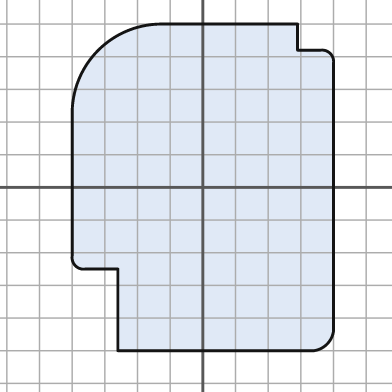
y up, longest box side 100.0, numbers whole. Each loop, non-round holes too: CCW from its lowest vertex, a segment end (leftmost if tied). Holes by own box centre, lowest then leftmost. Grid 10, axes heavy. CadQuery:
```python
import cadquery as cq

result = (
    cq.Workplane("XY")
    .moveTo(-26.0, -50.0)
    .lineTo(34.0, -50.0)
    .threePointArc((38.0, -48.0), (40.0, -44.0))
    .lineTo(40.0, 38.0)
    .threePointArc((39.0, 41.0), (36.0, 42.0))
    .lineTo(29.0, 42.0)
    .lineTo(29.0, 50.0)
    .lineTo(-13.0, 50.0)
    .threePointArc((-32.0, 42.0), (-40.0, 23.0))
    .lineTo(-40.0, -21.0)
    .threePointArc((-39.0, -24.0), (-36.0, -25.0))
    .lineTo(-26.0, -25.0)
    .close()
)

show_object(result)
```